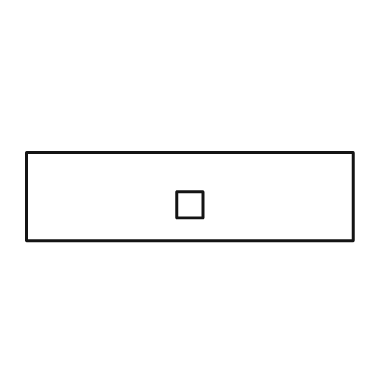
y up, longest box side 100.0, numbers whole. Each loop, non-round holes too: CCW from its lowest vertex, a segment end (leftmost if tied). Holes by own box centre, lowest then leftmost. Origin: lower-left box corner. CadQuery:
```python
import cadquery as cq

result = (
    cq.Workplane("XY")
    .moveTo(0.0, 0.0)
    .lineTo(100.0, 0.0)
    .lineTo(100.0, 27.0)
    .lineTo(0.0, 27.0)
    .close()
    .moveTo(46.0, 7.0)
    .lineTo(54.0, 7.0)
    .lineTo(54.0, 15.0)
    .lineTo(46.0, 15.0)
    .close()
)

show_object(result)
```